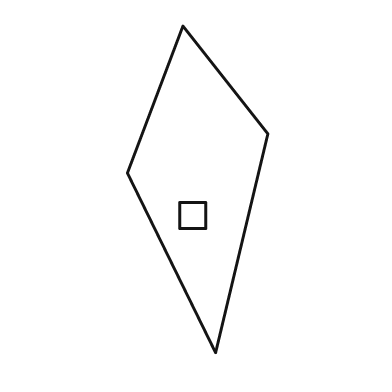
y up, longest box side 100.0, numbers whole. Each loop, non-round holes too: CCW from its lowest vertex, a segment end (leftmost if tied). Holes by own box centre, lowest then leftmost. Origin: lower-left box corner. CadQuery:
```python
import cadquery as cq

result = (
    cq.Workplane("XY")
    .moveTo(27.0, 0.0)
    .lineTo(43.0, 67.0)
    .lineTo(17.0, 100.0)
    .lineTo(0.0, 55.0)
    .close()
    .moveTo(16.0, 38.0)
    .lineTo(24.0, 38.0)
    .lineTo(24.0, 46.0)
    .lineTo(16.0, 46.0)
    .close()
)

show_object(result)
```